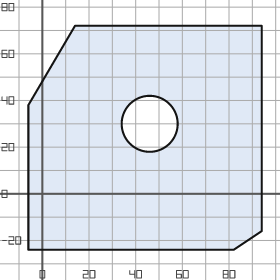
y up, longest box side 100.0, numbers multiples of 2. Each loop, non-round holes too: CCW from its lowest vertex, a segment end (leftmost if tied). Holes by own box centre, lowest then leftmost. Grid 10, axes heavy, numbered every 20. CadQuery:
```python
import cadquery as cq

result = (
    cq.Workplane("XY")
    .moveTo(-6.0, -24.0)
    .lineTo(82.0, -24.0)
    .lineTo(94.0, -16.0)
    .lineTo(94.0, 72.0)
    .lineTo(14.0, 72.0)
    .lineTo(-6.0, 38.0)
    .close()
    .moveTo(46.0, 30.0)
    .circle(12.0)
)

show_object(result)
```